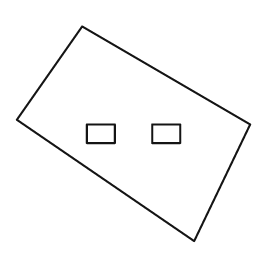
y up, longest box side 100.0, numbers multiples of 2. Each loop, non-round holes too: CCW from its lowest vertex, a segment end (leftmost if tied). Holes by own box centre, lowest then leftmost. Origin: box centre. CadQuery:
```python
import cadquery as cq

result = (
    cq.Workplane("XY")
    .moveTo(26.0, -46.0)
    .lineTo(50.0, 4.0)
    .lineTo(-22.0, 46.0)
    .lineTo(-50.0, 6.0)
    .close()
    .moveTo(-20.0, -4.0)
    .lineTo(-8.0, -4.0)
    .lineTo(-8.0, 4.0)
    .lineTo(-20.0, 4.0)
    .close()
    .moveTo(8.0, -4.0)
    .lineTo(20.0, -4.0)
    .lineTo(20.0, 4.0)
    .lineTo(8.0, 4.0)
    .close()
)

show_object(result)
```